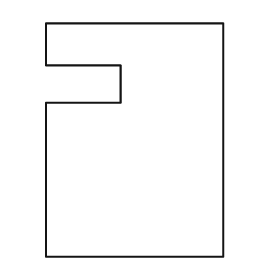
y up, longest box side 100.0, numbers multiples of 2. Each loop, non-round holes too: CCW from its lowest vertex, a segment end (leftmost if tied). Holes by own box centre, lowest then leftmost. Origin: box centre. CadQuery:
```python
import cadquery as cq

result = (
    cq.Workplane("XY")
    .moveTo(-38.0, -50.0)
    .lineTo(38.0, -50.0)
    .lineTo(38.0, 50.0)
    .lineTo(-38.0, 50.0)
    .lineTo(-38.0, 32.0)
    .lineTo(-6.0, 32.0)
    .lineTo(-6.0, 16.0)
    .lineTo(-38.0, 16.0)
    .close()
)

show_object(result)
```